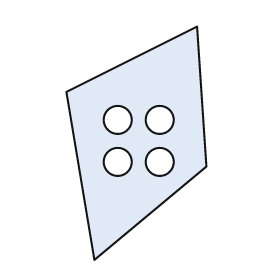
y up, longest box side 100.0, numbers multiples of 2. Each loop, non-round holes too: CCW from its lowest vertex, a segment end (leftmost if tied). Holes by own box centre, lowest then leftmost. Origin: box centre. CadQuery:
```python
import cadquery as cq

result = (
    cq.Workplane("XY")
    .moveTo(-18.0, -50.0)
    .lineTo(30.0, -10.0)
    .lineTo(26.0, 50.0)
    .lineTo(-30.0, 22.0)
    .close()
    .moveTo(-8.0, -8.0)
    .circle(6.0)
    .moveTo(10.0, -8.0)
    .circle(6.0)
    .moveTo(-8.0, 10.0)
    .circle(6.0)
    .moveTo(10.0, 10.0)
    .circle(6.0)
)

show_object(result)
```